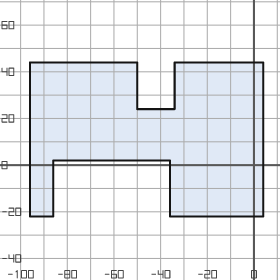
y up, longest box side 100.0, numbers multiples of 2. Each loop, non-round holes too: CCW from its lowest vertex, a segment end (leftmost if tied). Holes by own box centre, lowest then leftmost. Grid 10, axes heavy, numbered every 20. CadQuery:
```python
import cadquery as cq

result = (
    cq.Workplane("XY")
    .moveTo(-96.0, -22.0)
    .lineTo(-86.0, -22.0)
    .lineTo(-86.0, 2.0)
    .lineTo(-36.0, 2.0)
    .lineTo(-36.0, -22.0)
    .lineTo(4.0, -22.0)
    .lineTo(4.0, 44.0)
    .lineTo(-34.0, 44.0)
    .lineTo(-34.0, 24.0)
    .lineTo(-50.0, 24.0)
    .lineTo(-50.0, 44.0)
    .lineTo(-96.0, 44.0)
    .close()
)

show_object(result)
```